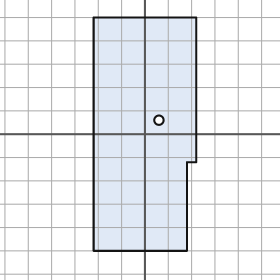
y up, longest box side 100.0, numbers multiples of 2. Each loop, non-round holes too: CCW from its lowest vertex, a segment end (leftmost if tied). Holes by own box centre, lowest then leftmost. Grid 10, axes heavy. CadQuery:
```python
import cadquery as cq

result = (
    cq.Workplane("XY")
    .moveTo(-22.0, -50.0)
    .lineTo(18.0, -50.0)
    .lineTo(18.0, -12.0)
    .lineTo(22.0, -12.0)
    .lineTo(22.0, 50.0)
    .lineTo(-22.0, 50.0)
    .close()
    .moveTo(6.0, 6.0)
    .circle(2.0)
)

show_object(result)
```